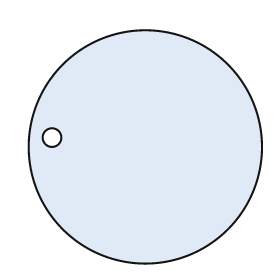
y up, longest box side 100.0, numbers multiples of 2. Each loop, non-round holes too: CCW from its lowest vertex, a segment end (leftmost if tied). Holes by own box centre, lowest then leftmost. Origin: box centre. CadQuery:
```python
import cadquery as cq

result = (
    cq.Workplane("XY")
    .moveTo(0.0, 0.0)
    .circle(50.0)
    .moveTo(-40.0, 4.0)
    .circle(4.0)
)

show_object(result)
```